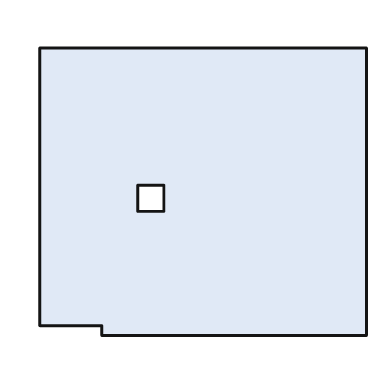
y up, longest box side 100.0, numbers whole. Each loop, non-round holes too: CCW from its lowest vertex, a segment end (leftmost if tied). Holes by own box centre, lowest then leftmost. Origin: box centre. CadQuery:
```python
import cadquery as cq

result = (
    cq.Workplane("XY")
    .moveTo(-31.0, -44.0)
    .lineTo(50.0, -44.0)
    .lineTo(50.0, 44.0)
    .lineTo(-50.0, 44.0)
    .lineTo(-50.0, -41.0)
    .lineTo(-31.0, -41.0)
    .close()
    .moveTo(-20.0, -6.0)
    .lineTo(-12.0, -6.0)
    .lineTo(-12.0, 2.0)
    .lineTo(-20.0, 2.0)
    .close()
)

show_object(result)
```